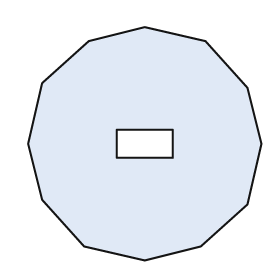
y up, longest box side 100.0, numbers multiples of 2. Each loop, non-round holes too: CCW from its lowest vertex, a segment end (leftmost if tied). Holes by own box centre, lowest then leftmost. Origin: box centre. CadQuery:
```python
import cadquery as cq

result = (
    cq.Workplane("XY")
    .moveTo(0.0, -50.0)
    .lineTo(24.0, -44.0)
    .lineTo(44.0, -26.0)
    .lineTo(50.0, 0.0)
    .lineTo(44.0, 24.0)
    .lineTo(26.0, 44.0)
    .lineTo(0.0, 50.0)
    .lineTo(-24.0, 44.0)
    .lineTo(-44.0, 26.0)
    .lineTo(-50.0, 0.0)
    .lineTo(-44.0, -24.0)
    .lineTo(-26.0, -44.0)
    .close()
    .moveTo(-12.0, -6.0)
    .lineTo(12.0, -6.0)
    .lineTo(12.0, 6.0)
    .lineTo(-12.0, 6.0)
    .close()
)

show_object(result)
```